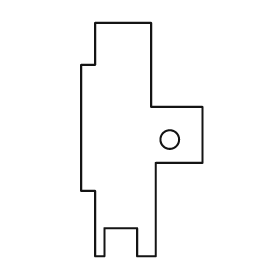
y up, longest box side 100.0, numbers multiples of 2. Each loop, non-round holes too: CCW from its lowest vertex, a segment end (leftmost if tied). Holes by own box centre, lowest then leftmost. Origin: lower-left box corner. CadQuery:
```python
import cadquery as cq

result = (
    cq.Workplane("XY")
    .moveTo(6.0, 0.0)
    .lineTo(10.0, 0.0)
    .lineTo(10.0, 12.0)
    .lineTo(24.0, 12.0)
    .lineTo(24.0, 0.0)
    .lineTo(32.0, 0.0)
    .lineTo(32.0, 40.0)
    .lineTo(52.0, 40.0)
    .lineTo(52.0, 64.0)
    .lineTo(30.0, 64.0)
    .lineTo(30.0, 100.0)
    .lineTo(6.0, 100.0)
    .lineTo(6.0, 82.0)
    .lineTo(0.0, 82.0)
    .lineTo(0.0, 28.0)
    .lineTo(6.0, 28.0)
    .close()
    .moveTo(38.0, 50.0)
    .circle(4.0)
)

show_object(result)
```